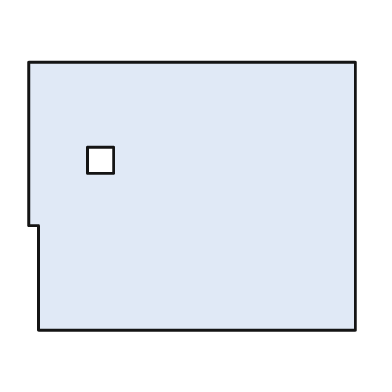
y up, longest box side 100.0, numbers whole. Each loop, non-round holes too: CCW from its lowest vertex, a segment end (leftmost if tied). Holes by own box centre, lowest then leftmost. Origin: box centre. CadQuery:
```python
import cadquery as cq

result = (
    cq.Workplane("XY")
    .moveTo(-47.0, -41.0)
    .lineTo(50.0, -41.0)
    .lineTo(50.0, 41.0)
    .lineTo(-50.0, 41.0)
    .lineTo(-50.0, -9.0)
    .lineTo(-47.0, -9.0)
    .close()
    .moveTo(-32.0, 7.0)
    .lineTo(-24.0, 7.0)
    .lineTo(-24.0, 15.0)
    .lineTo(-32.0, 15.0)
    .close()
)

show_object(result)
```